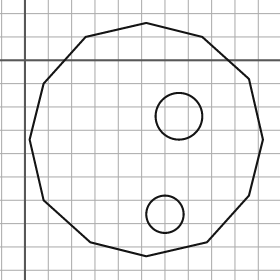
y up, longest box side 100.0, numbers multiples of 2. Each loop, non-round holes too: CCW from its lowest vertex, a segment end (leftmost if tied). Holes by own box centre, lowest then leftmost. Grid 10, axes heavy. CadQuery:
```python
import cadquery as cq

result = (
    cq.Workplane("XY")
    .moveTo(52.0, -84.0)
    .lineTo(78.0, -78.0)
    .lineTo(96.0, -58.0)
    .lineTo(102.0, -34.0)
    .lineTo(96.0, -8.0)
    .lineTo(76.0, 10.0)
    .lineTo(52.0, 16.0)
    .lineTo(26.0, 10.0)
    .lineTo(8.0, -10.0)
    .lineTo(2.0, -34.0)
    .lineTo(8.0, -60.0)
    .lineTo(28.0, -78.0)
    .close()
    .moveTo(60.0, -66.0)
    .circle(8.0)
    .moveTo(66.0, -24.0)
    .circle(10.0)
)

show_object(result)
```